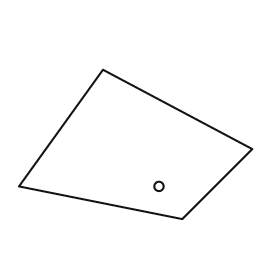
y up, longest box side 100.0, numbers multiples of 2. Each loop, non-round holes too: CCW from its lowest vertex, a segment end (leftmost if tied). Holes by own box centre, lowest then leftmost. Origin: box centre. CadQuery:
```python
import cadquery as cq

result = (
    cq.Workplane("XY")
    .moveTo(20.0, -32.0)
    .lineTo(50.0, -2.0)
    .lineTo(-14.0, 32.0)
    .lineTo(-50.0, -18.0)
    .close()
    .moveTo(10.0, -18.0)
    .circle(2.0)
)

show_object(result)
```